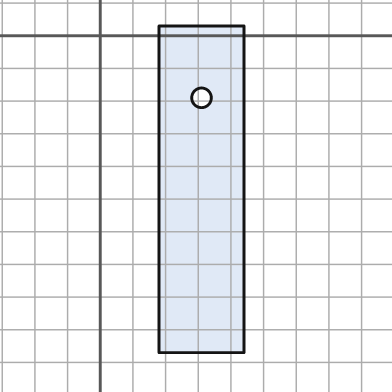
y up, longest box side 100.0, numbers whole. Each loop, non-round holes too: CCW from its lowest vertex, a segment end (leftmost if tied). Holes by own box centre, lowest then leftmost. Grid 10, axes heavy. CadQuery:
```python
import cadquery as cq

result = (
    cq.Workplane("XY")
    .moveTo(18.0, -97.0)
    .lineTo(44.0, -97.0)
    .lineTo(44.0, 3.0)
    .lineTo(18.0, 3.0)
    .close()
    .moveTo(31.0, -19.0)
    .circle(3.0)
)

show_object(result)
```